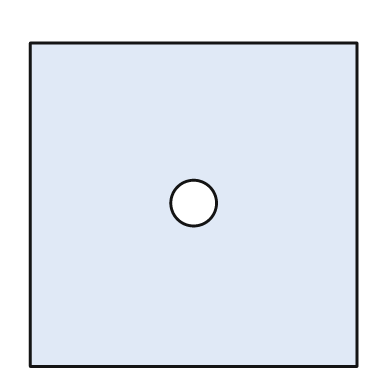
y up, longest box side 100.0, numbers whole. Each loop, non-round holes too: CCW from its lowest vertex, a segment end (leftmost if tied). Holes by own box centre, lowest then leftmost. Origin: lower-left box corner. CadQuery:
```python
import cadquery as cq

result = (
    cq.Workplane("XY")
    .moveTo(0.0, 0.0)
    .lineTo(100.0, 0.0)
    .lineTo(100.0, 99.0)
    .lineTo(0.0, 99.0)
    .close()
    .moveTo(50.0, 50.0)
    .circle(7.0)
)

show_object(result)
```